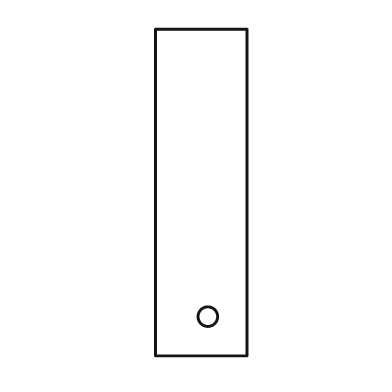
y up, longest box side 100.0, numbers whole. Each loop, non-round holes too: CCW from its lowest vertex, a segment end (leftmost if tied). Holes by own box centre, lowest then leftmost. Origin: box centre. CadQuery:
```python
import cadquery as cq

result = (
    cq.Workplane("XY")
    .moveTo(-14.0, -50.0)
    .lineTo(14.0, -50.0)
    .lineTo(14.0, 50.0)
    .lineTo(-14.0, 50.0)
    .close()
    .moveTo(2.0, -38.0)
    .circle(3.0)
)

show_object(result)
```